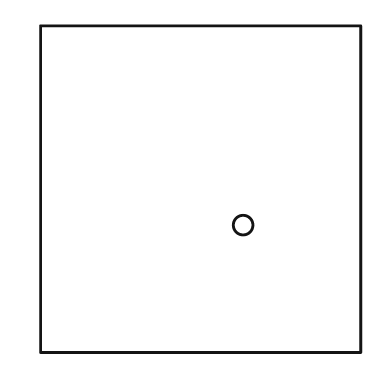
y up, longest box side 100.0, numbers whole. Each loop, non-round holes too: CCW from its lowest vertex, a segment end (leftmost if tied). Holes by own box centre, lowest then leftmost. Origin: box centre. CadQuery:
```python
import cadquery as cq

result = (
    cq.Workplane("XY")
    .moveTo(-49.0, -50.0)
    .lineTo(49.0, -50.0)
    .lineTo(49.0, 50.0)
    .lineTo(-49.0, 50.0)
    .close()
    .moveTo(13.0, -11.0)
    .circle(3.0)
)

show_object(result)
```